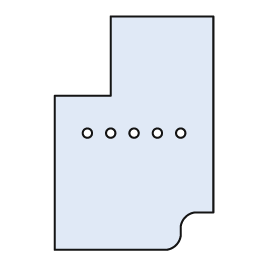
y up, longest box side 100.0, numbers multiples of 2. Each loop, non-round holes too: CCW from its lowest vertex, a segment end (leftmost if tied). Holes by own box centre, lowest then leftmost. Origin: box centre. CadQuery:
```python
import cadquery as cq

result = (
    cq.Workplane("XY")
    .moveTo(-34.0, -50.0)
    .lineTo(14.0, -50.0)
    .threePointArc((18.0, -48.0), (20.0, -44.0))
    .lineTo(20.0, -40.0)
    .threePointArc((22.0, -36.0), (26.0, -34.0))
    .lineTo(34.0, -34.0)
    .lineTo(34.0, 50.0)
    .lineTo(-10.0, 50.0)
    .lineTo(-10.0, 16.0)
    .lineTo(-34.0, 16.0)
    .close()
    .moveTo(-20.0, 0.0)
    .circle(2.0)
    .moveTo(-10.0, 0.0)
    .circle(2.0)
    .moveTo(0.0, 0.0)
    .circle(2.0)
    .moveTo(10.0, 0.0)
    .circle(2.0)
    .moveTo(20.0, 0.0)
    .circle(2.0)
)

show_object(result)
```